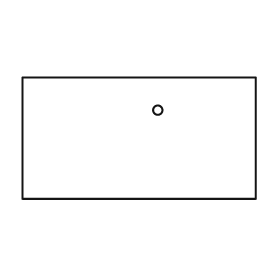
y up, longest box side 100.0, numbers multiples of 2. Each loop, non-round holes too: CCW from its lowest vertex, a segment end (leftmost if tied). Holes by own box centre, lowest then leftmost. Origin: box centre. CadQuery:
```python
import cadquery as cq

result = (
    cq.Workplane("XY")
    .moveTo(-50.0, -26.0)
    .lineTo(50.0, -26.0)
    .lineTo(50.0, 26.0)
    .lineTo(-50.0, 26.0)
    .close()
    .moveTo(8.0, 12.0)
    .circle(2.0)
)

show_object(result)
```